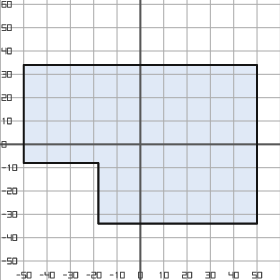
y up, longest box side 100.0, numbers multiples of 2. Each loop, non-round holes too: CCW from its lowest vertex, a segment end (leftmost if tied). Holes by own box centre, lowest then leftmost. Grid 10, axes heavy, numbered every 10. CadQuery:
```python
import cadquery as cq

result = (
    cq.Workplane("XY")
    .moveTo(-18.0, -34.0)
    .lineTo(50.0, -34.0)
    .lineTo(50.0, 34.0)
    .lineTo(-50.0, 34.0)
    .lineTo(-50.0, -8.0)
    .lineTo(-18.0, -8.0)
    .close()
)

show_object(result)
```